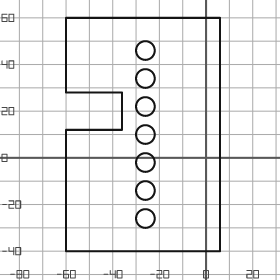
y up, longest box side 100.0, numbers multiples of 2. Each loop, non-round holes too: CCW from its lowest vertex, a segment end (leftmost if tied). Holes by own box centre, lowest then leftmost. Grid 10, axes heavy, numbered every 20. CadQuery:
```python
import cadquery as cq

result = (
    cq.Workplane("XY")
    .moveTo(-60.0, -40.0)
    .lineTo(6.0, -40.0)
    .lineTo(6.0, 60.0)
    .lineTo(-60.0, 60.0)
    .lineTo(-60.0, 28.0)
    .lineTo(-36.0, 28.0)
    .lineTo(-36.0, 12.0)
    .lineTo(-60.0, 12.0)
    .close()
    .moveTo(-26.0, -26.0)
    .circle(4.0)
    .moveTo(-26.0, -14.0)
    .circle(4.0)
    .moveTo(-26.0, -2.0)
    .circle(4.0)
    .moveTo(-26.0, 10.0)
    .circle(4.0)
    .moveTo(-26.0, 22.0)
    .circle(4.0)
    .moveTo(-26.0, 34.0)
    .circle(4.0)
    .moveTo(-26.0, 46.0)
    .circle(4.0)
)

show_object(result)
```